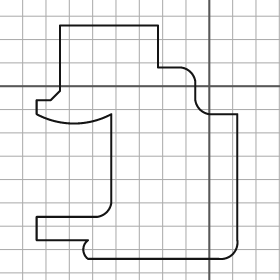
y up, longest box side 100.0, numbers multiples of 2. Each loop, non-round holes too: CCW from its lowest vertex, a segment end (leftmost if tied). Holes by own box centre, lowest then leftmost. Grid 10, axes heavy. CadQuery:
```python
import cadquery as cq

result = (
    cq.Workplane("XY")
    .moveTo(-52.0, -74.0)
    .lineTo(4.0, -74.0)
    .threePointArc((10.0, -72.0), (12.0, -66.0))
    .lineTo(12.0, -12.0)
    .lineTo(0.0, -12.0)
    .threePointArc((-4.0, -10.0), (-6.0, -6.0))
    .lineTo(-6.0, 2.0)
    .threePointArc((-8.0, 6.0), (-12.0, 8.0))
    .lineTo(-22.0, 8.0)
    .lineTo(-22.0, 26.0)
    .lineTo(-64.0, 26.0)
    .lineTo(-64.0, -2.0)
    .lineTo(-68.0, -6.0)
    .lineTo(-74.0, -6.0)
    .lineTo(-74.0, -12.0)
    .threePointArc((-58.0, -16.0), (-42.0, -12.0))
    .lineTo(-42.0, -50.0)
    .threePointArc((-44.0, -54.0), (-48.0, -56.0))
    .lineTo(-74.0, -56.0)
    .lineTo(-74.0, -66.0)
    .lineTo(-52.0, -66.0)
    .threePointArc((-54.0, -70.0), (-52.0, -74.0))
    .close()
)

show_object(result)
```